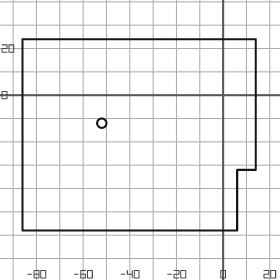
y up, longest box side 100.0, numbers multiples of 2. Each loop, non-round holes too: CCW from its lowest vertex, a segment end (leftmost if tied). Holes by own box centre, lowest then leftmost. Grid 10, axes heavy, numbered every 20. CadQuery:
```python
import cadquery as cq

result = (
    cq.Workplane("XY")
    .moveTo(-86.0, -58.0)
    .lineTo(6.0, -58.0)
    .lineTo(6.0, -32.0)
    .lineTo(14.0, -32.0)
    .lineTo(14.0, 24.0)
    .lineTo(-86.0, 24.0)
    .close()
    .moveTo(-52.0, -12.0)
    .circle(2.0)
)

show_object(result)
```